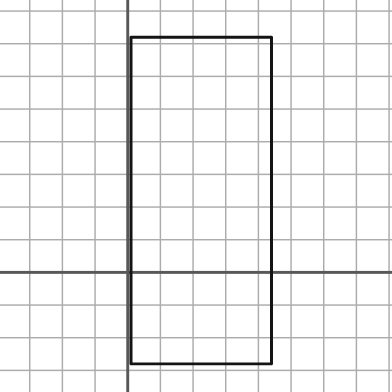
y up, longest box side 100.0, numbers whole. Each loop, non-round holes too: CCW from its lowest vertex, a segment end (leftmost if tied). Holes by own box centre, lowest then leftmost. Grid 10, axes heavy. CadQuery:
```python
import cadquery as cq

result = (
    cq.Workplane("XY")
    .moveTo(1.0, -28.0)
    .lineTo(44.0, -28.0)
    .lineTo(44.0, 72.0)
    .lineTo(1.0, 72.0)
    .close()
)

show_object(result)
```